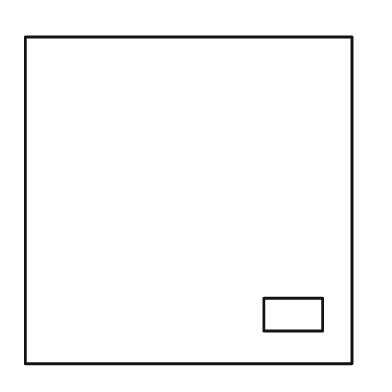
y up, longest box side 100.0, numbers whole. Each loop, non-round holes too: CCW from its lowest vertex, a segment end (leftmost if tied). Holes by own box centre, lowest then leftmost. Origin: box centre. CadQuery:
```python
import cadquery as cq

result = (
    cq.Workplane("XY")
    .moveTo(-50.0, -50.0)
    .lineTo(50.0, -50.0)
    .lineTo(50.0, 50.0)
    .lineTo(-50.0, 50.0)
    .close()
    .moveTo(23.0, -40.0)
    .lineTo(41.0, -40.0)
    .lineTo(41.0, -30.0)
    .lineTo(23.0, -30.0)
    .close()
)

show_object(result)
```